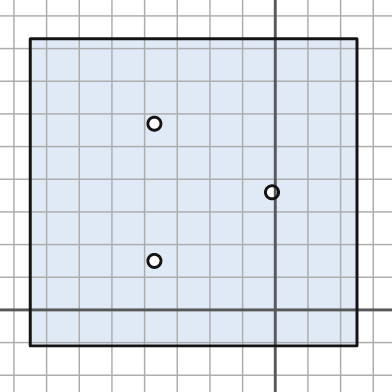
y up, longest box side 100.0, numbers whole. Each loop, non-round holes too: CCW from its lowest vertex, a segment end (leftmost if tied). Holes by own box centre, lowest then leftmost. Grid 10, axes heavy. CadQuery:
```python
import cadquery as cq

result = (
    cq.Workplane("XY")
    .moveTo(-75.0, -11.0)
    .lineTo(25.0, -11.0)
    .lineTo(25.0, 83.0)
    .lineTo(-75.0, 83.0)
    .close()
    .moveTo(-37.0, 15.0)
    .circle(2.0)
    .moveTo(-1.0, 36.0)
    .circle(2.0)
    .moveTo(-37.0, 57.0)
    .circle(2.0)
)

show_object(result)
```